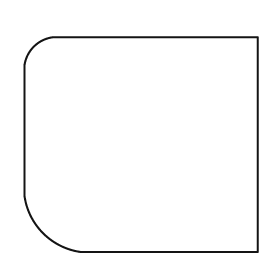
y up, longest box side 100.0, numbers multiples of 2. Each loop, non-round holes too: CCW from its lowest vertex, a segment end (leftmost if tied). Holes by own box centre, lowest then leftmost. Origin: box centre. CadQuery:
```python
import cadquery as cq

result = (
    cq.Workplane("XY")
    .moveTo(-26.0, -46.0)
    .lineTo(50.0, -46.0)
    .lineTo(50.0, 46.0)
    .lineTo(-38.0, 46.0)
    .threePointArc((-46.0, 42.0), (-50.0, 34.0))
    .lineTo(-50.0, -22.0)
    .threePointArc((-42.0, -38.0), (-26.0, -46.0))
    .close()
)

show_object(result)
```